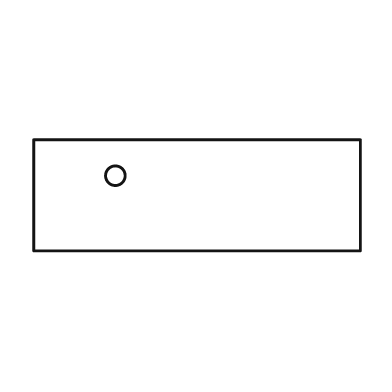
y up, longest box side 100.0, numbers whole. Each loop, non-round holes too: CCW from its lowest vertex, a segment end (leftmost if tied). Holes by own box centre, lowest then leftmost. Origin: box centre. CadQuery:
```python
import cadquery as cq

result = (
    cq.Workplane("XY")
    .moveTo(-50.0, -17.0)
    .lineTo(50.0, -17.0)
    .lineTo(50.0, 17.0)
    .lineTo(-50.0, 17.0)
    .close()
    .moveTo(-25.0, 6.0)
    .circle(3.0)
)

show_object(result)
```